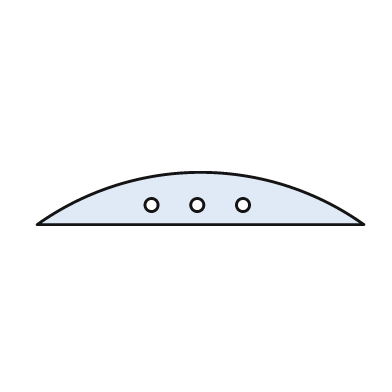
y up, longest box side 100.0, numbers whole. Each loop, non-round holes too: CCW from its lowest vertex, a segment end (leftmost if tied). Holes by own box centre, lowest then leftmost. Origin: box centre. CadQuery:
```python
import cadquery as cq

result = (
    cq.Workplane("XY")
    .moveTo(-50.0, -8.0)
    .lineTo(50.0, -8.0)
    .threePointArc((0.0, 8.0), (-50.0, -8.0))
    .close()
    .moveTo(-15.0, -2.0)
    .circle(2.0)
    .moveTo(-1.0, -2.0)
    .circle(2.0)
    .moveTo(13.0, -2.0)
    .circle(2.0)
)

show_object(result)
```